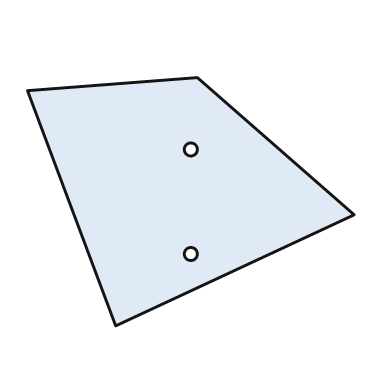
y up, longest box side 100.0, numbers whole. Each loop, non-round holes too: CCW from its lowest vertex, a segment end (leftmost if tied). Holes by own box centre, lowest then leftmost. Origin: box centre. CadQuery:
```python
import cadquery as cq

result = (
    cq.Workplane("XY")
    .moveTo(-23.0, -38.0)
    .lineTo(50.0, -4.0)
    .lineTo(2.0, 38.0)
    .lineTo(-50.0, 34.0)
    .close()
    .moveTo(0.0, -16.0)
    .circle(2.0)
    .moveTo(0.0, 16.0)
    .circle(2.0)
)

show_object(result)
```